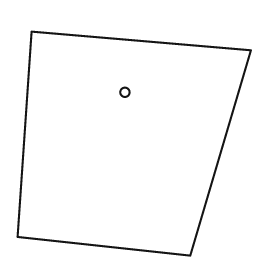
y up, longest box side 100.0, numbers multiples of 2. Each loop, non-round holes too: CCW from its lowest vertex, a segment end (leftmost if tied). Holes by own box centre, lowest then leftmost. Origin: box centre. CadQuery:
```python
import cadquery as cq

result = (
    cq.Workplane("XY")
    .moveTo(24.0, -48.0)
    .lineTo(50.0, 40.0)
    .lineTo(-44.0, 48.0)
    .lineTo(-50.0, -40.0)
    .close()
    .moveTo(-4.0, 22.0)
    .circle(2.0)
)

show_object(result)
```